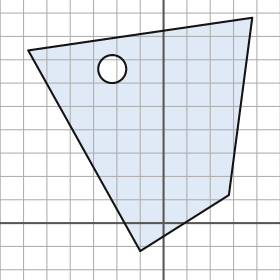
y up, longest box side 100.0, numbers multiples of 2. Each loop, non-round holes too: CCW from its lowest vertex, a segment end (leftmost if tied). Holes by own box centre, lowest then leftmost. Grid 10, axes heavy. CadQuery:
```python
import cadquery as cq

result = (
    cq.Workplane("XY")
    .moveTo(-10.0, -12.0)
    .lineTo(28.0, 12.0)
    .lineTo(38.0, 88.0)
    .lineTo(-58.0, 74.0)
    .close()
    .moveTo(-22.0, 66.0)
    .circle(6.0)
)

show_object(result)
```